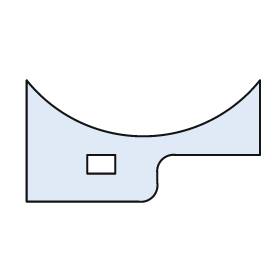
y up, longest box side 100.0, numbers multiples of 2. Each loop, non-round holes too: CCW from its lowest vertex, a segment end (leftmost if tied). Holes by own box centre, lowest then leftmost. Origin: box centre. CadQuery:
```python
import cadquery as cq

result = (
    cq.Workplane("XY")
    .moveTo(-50.0, -26.0)
    .lineTo(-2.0, -26.0)
    .threePointArc((4.0, -24.0), (6.0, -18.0))
    .lineTo(6.0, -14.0)
    .threePointArc((8.0, -8.0), (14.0, -6.0))
    .lineTo(50.0, -6.0)
    .lineTo(50.0, 26.0)
    .threePointArc((0.0, 2.0), (-50.0, 26.0))
    .close()
    .moveTo(-24.0, -14.0)
    .lineTo(-12.0, -14.0)
    .lineTo(-12.0, -6.0)
    .lineTo(-24.0, -6.0)
    .close()
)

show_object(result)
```